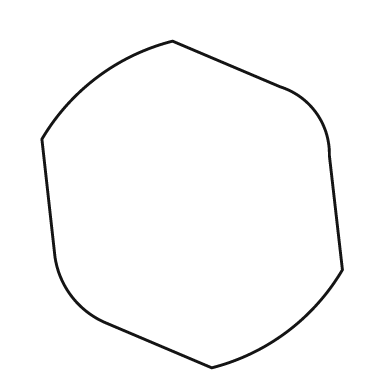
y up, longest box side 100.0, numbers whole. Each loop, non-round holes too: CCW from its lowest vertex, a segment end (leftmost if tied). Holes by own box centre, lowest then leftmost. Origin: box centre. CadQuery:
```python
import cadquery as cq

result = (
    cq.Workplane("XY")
    .moveTo(6.0, -50.0)
    .threePointArc((29.0, -39.0), (46.0, -20.0))
    .lineTo(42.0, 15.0)
    .threePointArc((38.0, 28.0), (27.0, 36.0))
    .lineTo(-6.0, 50.0)
    .threePointArc((-29.0, 39.0), (-46.0, 20.0))
    .lineTo(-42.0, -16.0)
    .threePointArc((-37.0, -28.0), (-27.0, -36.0))
    .close()
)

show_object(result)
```